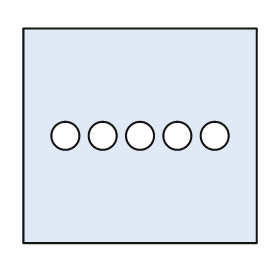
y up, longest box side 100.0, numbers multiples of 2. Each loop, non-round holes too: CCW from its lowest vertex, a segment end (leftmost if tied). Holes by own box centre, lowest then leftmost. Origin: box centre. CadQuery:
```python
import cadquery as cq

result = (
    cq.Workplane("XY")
    .moveTo(-50.0, -46.0)
    .lineTo(50.0, -46.0)
    .lineTo(50.0, 46.0)
    .lineTo(-50.0, 46.0)
    .close()
    .moveTo(-32.0, 0.0)
    .circle(6.0)
    .moveTo(-16.0, 0.0)
    .circle(6.0)
    .moveTo(0.0, 0.0)
    .circle(6.0)
    .moveTo(16.0, 0.0)
    .circle(6.0)
    .moveTo(32.0, 0.0)
    .circle(6.0)
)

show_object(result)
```